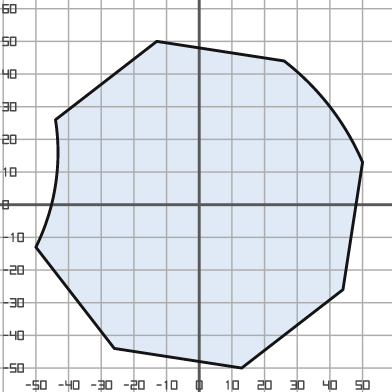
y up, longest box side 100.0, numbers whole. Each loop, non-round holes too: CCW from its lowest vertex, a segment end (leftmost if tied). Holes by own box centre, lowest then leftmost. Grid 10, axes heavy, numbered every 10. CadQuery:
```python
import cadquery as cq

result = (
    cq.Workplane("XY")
    .moveTo(13.0, -50.0)
    .lineTo(44.0, -26.0)
    .lineTo(50.0, 13.0)
    .threePointArc((40.0, 30.0), (26.0, 44.0))
    .lineTo(-13.0, 50.0)
    .lineTo(-44.0, 26.0)
    .threePointArc((-44.0, 6.0), (-50.0, -13.0))
    .lineTo(-26.0, -44.0)
    .close()
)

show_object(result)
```